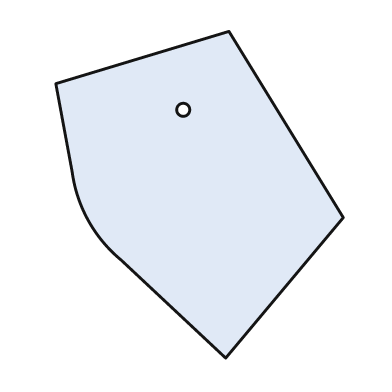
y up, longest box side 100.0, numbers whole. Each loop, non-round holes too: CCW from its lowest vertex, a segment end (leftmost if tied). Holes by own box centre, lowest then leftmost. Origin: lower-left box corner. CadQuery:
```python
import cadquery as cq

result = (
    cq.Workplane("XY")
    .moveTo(52.0, 0.0)
    .lineTo(88.0, 43.0)
    .lineTo(53.0, 100.0)
    .lineTo(0.0, 84.0)
    .lineTo(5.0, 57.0)
    .threePointArc((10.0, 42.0), (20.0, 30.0))
    .close()
    .moveTo(39.0, 76.0)
    .circle(2.0)
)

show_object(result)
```